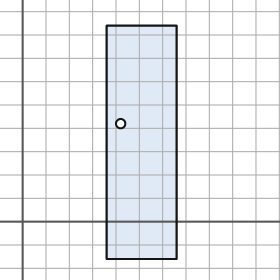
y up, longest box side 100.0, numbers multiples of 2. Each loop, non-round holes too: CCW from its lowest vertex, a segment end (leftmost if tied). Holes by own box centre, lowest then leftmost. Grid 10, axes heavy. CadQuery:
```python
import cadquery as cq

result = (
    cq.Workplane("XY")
    .moveTo(36.0, -16.0)
    .lineTo(66.0, -16.0)
    .lineTo(66.0, 84.0)
    .lineTo(36.0, 84.0)
    .close()
    .moveTo(42.0, 42.0)
    .circle(2.0)
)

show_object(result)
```